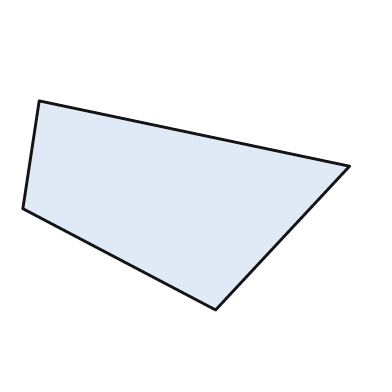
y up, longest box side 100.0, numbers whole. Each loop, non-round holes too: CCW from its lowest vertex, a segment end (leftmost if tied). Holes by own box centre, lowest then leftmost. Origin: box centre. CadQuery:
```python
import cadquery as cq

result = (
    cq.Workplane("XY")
    .moveTo(9.0, -32.0)
    .lineTo(50.0, 12.0)
    .lineTo(-45.0, 32.0)
    .lineTo(-50.0, -1.0)
    .close()
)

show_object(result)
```